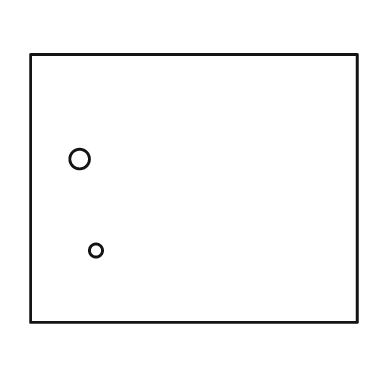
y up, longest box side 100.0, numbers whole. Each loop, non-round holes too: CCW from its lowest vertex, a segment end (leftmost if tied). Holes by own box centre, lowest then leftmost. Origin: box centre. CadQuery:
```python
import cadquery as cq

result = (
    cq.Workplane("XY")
    .moveTo(-50.0, -41.0)
    .lineTo(50.0, -41.0)
    .lineTo(50.0, 41.0)
    .lineTo(-50.0, 41.0)
    .close()
    .moveTo(-30.0, -19.0)
    .circle(2.0)
    .moveTo(-35.0, 9.0)
    .circle(3.0)
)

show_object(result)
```